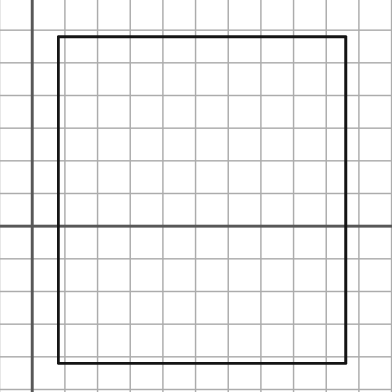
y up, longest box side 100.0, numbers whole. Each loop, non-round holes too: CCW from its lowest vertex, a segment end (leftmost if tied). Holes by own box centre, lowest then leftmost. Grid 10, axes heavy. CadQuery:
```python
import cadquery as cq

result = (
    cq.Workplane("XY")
    .moveTo(8.0, -42.0)
    .lineTo(96.0, -42.0)
    .lineTo(96.0, 58.0)
    .lineTo(8.0, 58.0)
    .close()
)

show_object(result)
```